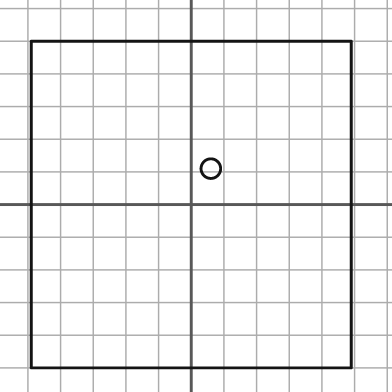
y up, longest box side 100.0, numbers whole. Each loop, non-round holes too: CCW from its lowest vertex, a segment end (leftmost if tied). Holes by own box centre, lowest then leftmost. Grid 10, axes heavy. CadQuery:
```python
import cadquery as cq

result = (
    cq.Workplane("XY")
    .moveTo(-49.0, -50.0)
    .lineTo(49.0, -50.0)
    .lineTo(49.0, 50.0)
    .lineTo(-49.0, 50.0)
    .close()
    .moveTo(6.0, 11.0)
    .circle(3.0)
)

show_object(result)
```